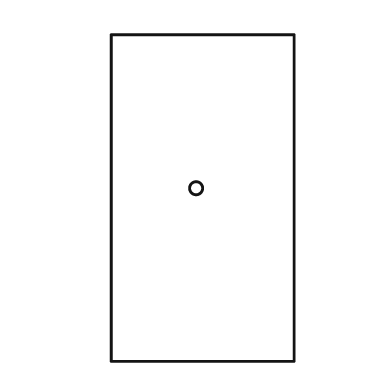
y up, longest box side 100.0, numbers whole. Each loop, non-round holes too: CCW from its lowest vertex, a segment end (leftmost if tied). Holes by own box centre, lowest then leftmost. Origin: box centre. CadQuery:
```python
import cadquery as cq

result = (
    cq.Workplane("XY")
    .moveTo(-28.0, -50.0)
    .lineTo(28.0, -50.0)
    .lineTo(28.0, 50.0)
    .lineTo(-28.0, 50.0)
    .close()
    .moveTo(-2.0, 3.0)
    .circle(2.0)
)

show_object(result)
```